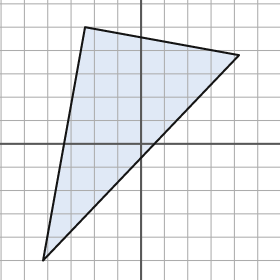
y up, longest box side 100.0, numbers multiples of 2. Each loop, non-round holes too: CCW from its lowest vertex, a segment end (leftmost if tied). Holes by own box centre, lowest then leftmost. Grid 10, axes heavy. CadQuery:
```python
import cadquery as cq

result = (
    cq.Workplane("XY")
    .moveTo(-42.0, -50.0)
    .lineTo(42.0, 38.0)
    .lineTo(-24.0, 50.0)
    .close()
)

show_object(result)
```